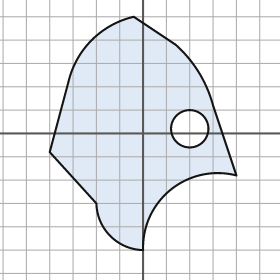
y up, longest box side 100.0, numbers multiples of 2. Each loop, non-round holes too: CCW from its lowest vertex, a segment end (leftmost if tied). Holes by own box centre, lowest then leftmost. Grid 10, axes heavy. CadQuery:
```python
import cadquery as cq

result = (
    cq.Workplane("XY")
    .moveTo(0.0, -50.0)
    .threePointArc((12.0, -24.0), (40.0, -18.0))
    .lineTo(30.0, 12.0)
    .threePointArc((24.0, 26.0), (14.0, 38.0))
    .lineTo(-4.0, 50.0)
    .threePointArc((-22.0, 40.0), (-32.0, 22.0))
    .lineTo(-40.0, -8.0)
    .lineTo(-20.0, -30.0)
    .threePointArc((-14.0, -44.0), (0.0, -50.0))
    .close()
    .moveTo(20.0, 2.0)
    .circle(8.0)
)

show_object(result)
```